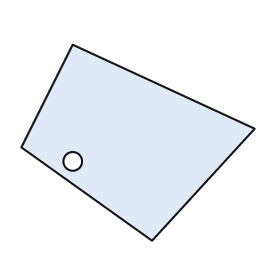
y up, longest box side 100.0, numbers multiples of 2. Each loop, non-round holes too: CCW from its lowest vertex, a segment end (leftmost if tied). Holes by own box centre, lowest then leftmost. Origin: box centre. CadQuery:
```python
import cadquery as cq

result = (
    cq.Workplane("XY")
    .moveTo(6.0, -42.0)
    .lineTo(50.0, 6.0)
    .lineTo(-28.0, 42.0)
    .lineTo(-50.0, -2.0)
    .close()
    .moveTo(-28.0, -8.0)
    .circle(4.0)
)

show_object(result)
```